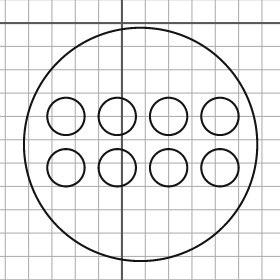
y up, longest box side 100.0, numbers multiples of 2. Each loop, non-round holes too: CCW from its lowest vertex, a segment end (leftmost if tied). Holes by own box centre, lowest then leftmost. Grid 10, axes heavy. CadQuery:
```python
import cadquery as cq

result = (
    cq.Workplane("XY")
    .moveTo(8.0, -52.0)
    .circle(50.0)
    .moveTo(-24.0, -62.0)
    .circle(8.0)
    .moveTo(-2.0, -62.0)
    .circle(8.0)
    .moveTo(20.0, -62.0)
    .circle(8.0)
    .moveTo(42.0, -62.0)
    .circle(8.0)
    .moveTo(-24.0, -40.0)
    .circle(8.0)
    .moveTo(-2.0, -40.0)
    .circle(8.0)
    .moveTo(20.0, -40.0)
    .circle(8.0)
    .moveTo(42.0, -40.0)
    .circle(8.0)
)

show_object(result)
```